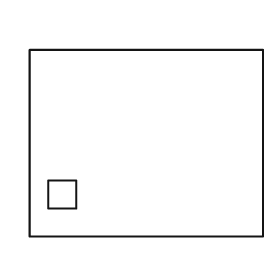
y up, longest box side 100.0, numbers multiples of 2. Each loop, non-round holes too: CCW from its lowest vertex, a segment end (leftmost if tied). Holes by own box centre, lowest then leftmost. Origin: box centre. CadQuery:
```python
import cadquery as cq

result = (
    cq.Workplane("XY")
    .moveTo(-50.0, -40.0)
    .lineTo(50.0, -40.0)
    .lineTo(50.0, 40.0)
    .lineTo(-50.0, 40.0)
    .close()
    .moveTo(-42.0, -28.0)
    .lineTo(-30.0, -28.0)
    .lineTo(-30.0, -16.0)
    .lineTo(-42.0, -16.0)
    .close()
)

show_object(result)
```